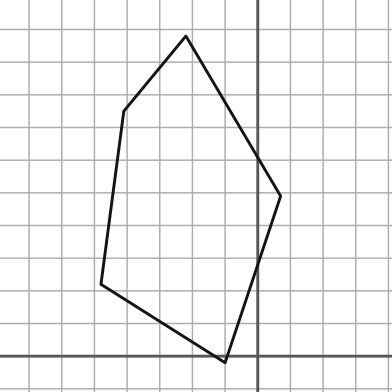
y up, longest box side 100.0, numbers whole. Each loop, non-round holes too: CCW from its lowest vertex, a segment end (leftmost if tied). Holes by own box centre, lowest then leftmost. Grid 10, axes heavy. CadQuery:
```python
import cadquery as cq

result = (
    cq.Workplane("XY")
    .moveTo(-10.0, -2.0)
    .lineTo(7.0, 49.0)
    .lineTo(-22.0, 98.0)
    .lineTo(-41.0, 75.0)
    .lineTo(-48.0, 22.0)
    .close()
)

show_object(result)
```